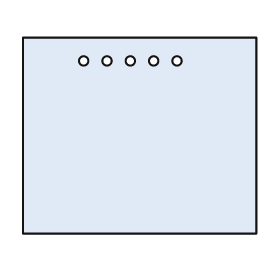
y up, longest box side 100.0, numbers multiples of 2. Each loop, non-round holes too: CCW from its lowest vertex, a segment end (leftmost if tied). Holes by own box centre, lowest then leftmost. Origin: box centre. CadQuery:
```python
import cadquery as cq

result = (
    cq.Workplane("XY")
    .moveTo(-50.0, -42.0)
    .lineTo(50.0, -42.0)
    .lineTo(50.0, 42.0)
    .lineTo(-50.0, 42.0)
    .close()
    .moveTo(-24.0, 32.0)
    .circle(2.0)
    .moveTo(-14.0, 32.0)
    .circle(2.0)
    .moveTo(-4.0, 32.0)
    .circle(2.0)
    .moveTo(6.0, 32.0)
    .circle(2.0)
    .moveTo(16.0, 32.0)
    .circle(2.0)
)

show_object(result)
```